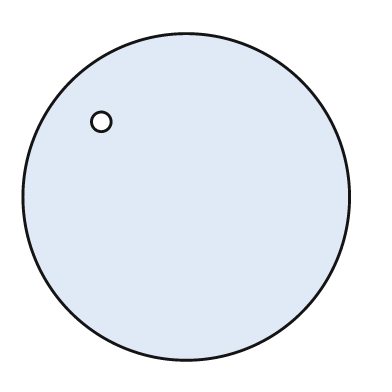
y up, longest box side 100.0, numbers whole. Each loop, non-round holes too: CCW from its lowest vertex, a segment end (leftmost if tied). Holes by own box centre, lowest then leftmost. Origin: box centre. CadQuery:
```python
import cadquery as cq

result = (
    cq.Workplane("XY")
    .moveTo(0.0, 0.0)
    .circle(50.0)
    .moveTo(-26.0, 23.0)
    .circle(3.0)
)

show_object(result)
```